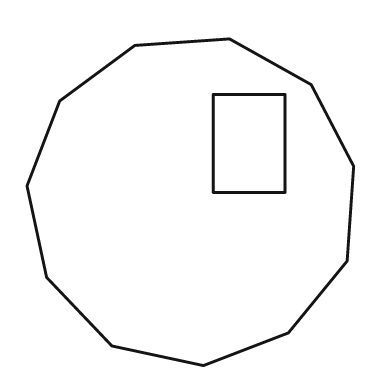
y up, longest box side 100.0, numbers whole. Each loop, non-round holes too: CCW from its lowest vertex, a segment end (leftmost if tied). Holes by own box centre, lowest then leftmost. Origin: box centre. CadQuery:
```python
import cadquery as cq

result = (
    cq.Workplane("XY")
    .moveTo(4.0, -50.0)
    .lineTo(30.0, -40.0)
    .lineTo(48.0, -18.0)
    .lineTo(50.0, 11.0)
    .lineTo(37.0, 36.0)
    .lineTo(12.0, 50.0)
    .lineTo(-17.0, 48.0)
    .lineTo(-40.0, 31.0)
    .lineTo(-50.0, 5.0)
    .lineTo(-44.0, -23.0)
    .lineTo(-24.0, -44.0)
    .close()
    .moveTo(7.0, 3.0)
    .lineTo(29.0, 3.0)
    .lineTo(29.0, 33.0)
    .lineTo(7.0, 33.0)
    .close()
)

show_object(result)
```